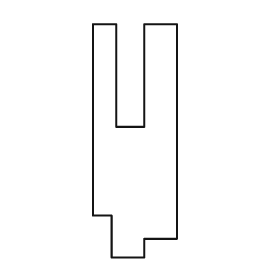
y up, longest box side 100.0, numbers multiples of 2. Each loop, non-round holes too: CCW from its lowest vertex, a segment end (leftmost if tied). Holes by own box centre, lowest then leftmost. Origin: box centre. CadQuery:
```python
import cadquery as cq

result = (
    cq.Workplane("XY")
    .moveTo(-10.0, -50.0)
    .lineTo(4.0, -50.0)
    .lineTo(4.0, -42.0)
    .lineTo(18.0, -42.0)
    .lineTo(18.0, 50.0)
    .lineTo(4.0, 50.0)
    .lineTo(4.0, 6.0)
    .lineTo(-8.0, 6.0)
    .lineTo(-8.0, 50.0)
    .lineTo(-18.0, 50.0)
    .lineTo(-18.0, -32.0)
    .lineTo(-10.0, -32.0)
    .close()
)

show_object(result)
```